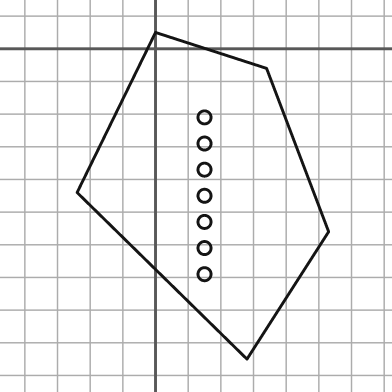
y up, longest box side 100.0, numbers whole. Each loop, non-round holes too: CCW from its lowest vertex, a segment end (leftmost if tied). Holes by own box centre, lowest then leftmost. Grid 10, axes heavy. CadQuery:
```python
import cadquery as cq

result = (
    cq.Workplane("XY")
    .moveTo(28.0, -95.0)
    .lineTo(53.0, -56.0)
    .lineTo(34.0, -6.0)
    .lineTo(0.0, 5.0)
    .lineTo(-24.0, -44.0)
    .close()
    .moveTo(15.0, -69.0)
    .circle(2.0)
    .moveTo(15.0, -61.0)
    .circle(2.0)
    .moveTo(15.0, -53.0)
    .circle(2.0)
    .moveTo(15.0, -45.0)
    .circle(2.0)
    .moveTo(15.0, -37.0)
    .circle(2.0)
    .moveTo(15.0, -29.0)
    .circle(2.0)
    .moveTo(15.0, -21.0)
    .circle(2.0)
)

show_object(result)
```